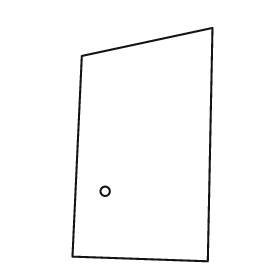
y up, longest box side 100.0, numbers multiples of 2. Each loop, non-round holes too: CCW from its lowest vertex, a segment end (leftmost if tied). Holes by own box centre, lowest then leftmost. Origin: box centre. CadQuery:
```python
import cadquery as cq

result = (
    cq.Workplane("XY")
    .moveTo(28.0, -50.0)
    .lineTo(30.0, 50.0)
    .lineTo(-26.0, 38.0)
    .lineTo(-30.0, -48.0)
    .close()
    .moveTo(-16.0, -20.0)
    .circle(2.0)
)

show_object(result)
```